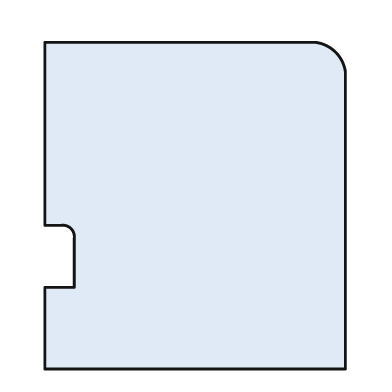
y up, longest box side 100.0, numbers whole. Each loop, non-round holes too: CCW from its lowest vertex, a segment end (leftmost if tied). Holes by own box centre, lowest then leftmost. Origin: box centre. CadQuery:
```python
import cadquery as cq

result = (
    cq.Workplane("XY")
    .moveTo(-46.0, -50.0)
    .lineTo(46.0, -50.0)
    .lineTo(46.0, 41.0)
    .threePointArc((43.0, 47.0), (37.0, 50.0))
    .lineTo(-46.0, 50.0)
    .lineTo(-46.0, -6.0)
    .lineTo(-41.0, -6.0)
    .threePointArc((-38.0, -7.0), (-37.0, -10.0))
    .lineTo(-37.0, -25.0)
    .lineTo(-46.0, -25.0)
    .close()
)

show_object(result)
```